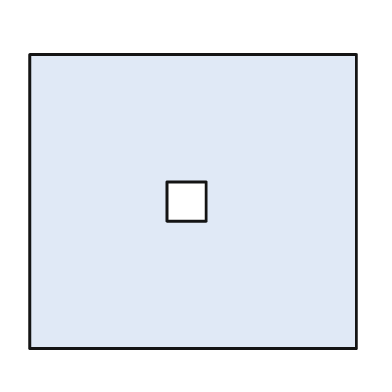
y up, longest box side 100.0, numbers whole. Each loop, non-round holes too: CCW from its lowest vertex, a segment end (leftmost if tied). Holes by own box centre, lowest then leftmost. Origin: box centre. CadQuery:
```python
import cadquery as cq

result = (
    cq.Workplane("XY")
    .moveTo(-50.0, -45.0)
    .lineTo(50.0, -45.0)
    .lineTo(50.0, 45.0)
    .lineTo(-50.0, 45.0)
    .close()
    .moveTo(-8.0, -6.0)
    .lineTo(4.0, -6.0)
    .lineTo(4.0, 6.0)
    .lineTo(-8.0, 6.0)
    .close()
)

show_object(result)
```